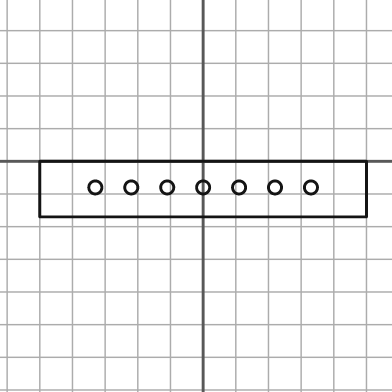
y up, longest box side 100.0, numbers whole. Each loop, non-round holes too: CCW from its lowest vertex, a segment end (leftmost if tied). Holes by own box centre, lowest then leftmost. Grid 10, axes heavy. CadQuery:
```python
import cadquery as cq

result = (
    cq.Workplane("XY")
    .moveTo(-50.0, -17.0)
    .lineTo(50.0, -17.0)
    .lineTo(50.0, 0.0)
    .lineTo(-50.0, 0.0)
    .close()
    .moveTo(-33.0, -8.0)
    .circle(2.0)
    .moveTo(-22.0, -8.0)
    .circle(2.0)
    .moveTo(-11.0, -8.0)
    .circle(2.0)
    .moveTo(0.0, -8.0)
    .circle(2.0)
    .moveTo(11.0, -8.0)
    .circle(2.0)
    .moveTo(22.0, -8.0)
    .circle(2.0)
    .moveTo(33.0, -8.0)
    .circle(2.0)
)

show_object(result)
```